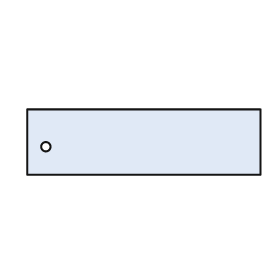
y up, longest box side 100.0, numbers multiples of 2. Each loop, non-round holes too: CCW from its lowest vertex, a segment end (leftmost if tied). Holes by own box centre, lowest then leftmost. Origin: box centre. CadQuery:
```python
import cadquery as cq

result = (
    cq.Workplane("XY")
    .moveTo(-50.0, -14.0)
    .lineTo(50.0, -14.0)
    .lineTo(50.0, 14.0)
    .lineTo(-50.0, 14.0)
    .close()
    .moveTo(-42.0, -2.0)
    .circle(2.0)
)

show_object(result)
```